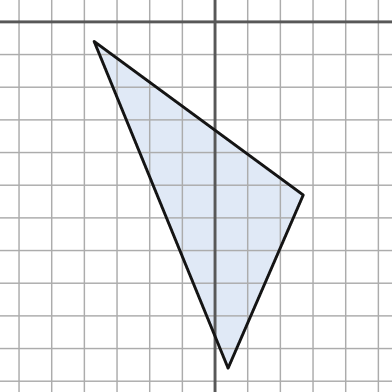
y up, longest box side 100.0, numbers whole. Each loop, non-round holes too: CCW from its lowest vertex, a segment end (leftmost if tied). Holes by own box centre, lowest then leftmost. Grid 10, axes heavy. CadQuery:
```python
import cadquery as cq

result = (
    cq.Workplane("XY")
    .moveTo(4.0, -106.0)
    .lineTo(27.0, -53.0)
    .lineTo(-37.0, -6.0)
    .close()
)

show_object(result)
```